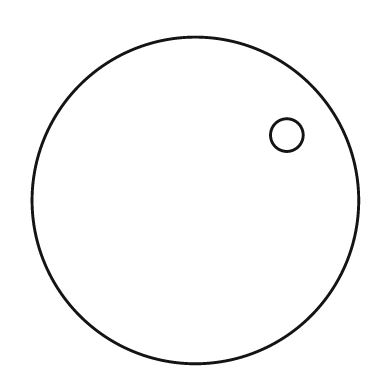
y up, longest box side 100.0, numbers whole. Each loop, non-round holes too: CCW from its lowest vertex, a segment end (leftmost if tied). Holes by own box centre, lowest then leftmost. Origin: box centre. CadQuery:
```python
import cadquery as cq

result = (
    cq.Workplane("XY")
    .moveTo(0.0, 0.0)
    .circle(50.0)
    .moveTo(28.0, 20.0)
    .circle(5.0)
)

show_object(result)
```